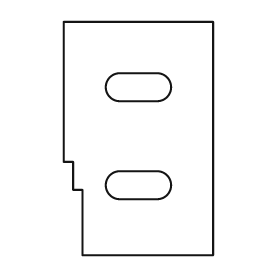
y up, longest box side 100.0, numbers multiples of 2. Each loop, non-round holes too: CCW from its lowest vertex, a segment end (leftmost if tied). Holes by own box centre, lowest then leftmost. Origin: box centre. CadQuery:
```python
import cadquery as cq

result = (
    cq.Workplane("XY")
    .moveTo(-24.0, -50.0)
    .lineTo(32.0, -50.0)
    .lineTo(32.0, 50.0)
    .lineTo(-32.0, 50.0)
    .lineTo(-32.0, -10.0)
    .lineTo(-28.0, -10.0)
    .lineTo(-28.0, -22.0)
    .lineTo(-24.0, -22.0)
    .close()
    .moveTo(-8.0, -26.0)
    .lineTo(8.0, -26.0)
    .threePointArc((14.0, -20.0), (8.0, -14.0))
    .lineTo(-8.0, -14.0)
    .threePointArc((-14.0, -20.0), (-8.0, -26.0))
    .close()
    .moveTo(-8.0, 16.0)
    .lineTo(8.0, 16.0)
    .threePointArc((14.0, 22.0), (8.0, 28.0))
    .lineTo(-8.0, 28.0)
    .threePointArc((-14.0, 22.0), (-8.0, 16.0))
    .close()
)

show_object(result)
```